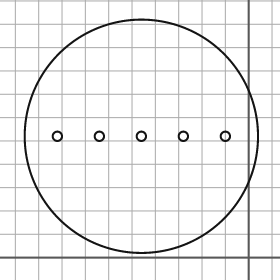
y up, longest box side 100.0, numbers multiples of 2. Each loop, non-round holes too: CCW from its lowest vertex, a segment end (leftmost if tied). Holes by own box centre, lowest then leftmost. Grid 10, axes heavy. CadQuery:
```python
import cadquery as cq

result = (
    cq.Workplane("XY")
    .moveTo(-46.0, 52.0)
    .circle(50.0)
    .moveTo(-82.0, 52.0)
    .circle(2.0)
    .moveTo(-64.0, 52.0)
    .circle(2.0)
    .moveTo(-46.0, 52.0)
    .circle(2.0)
    .moveTo(-28.0, 52.0)
    .circle(2.0)
    .moveTo(-10.0, 52.0)
    .circle(2.0)
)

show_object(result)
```